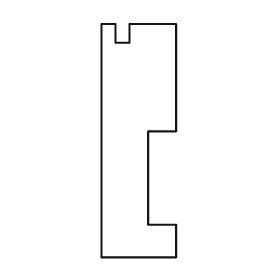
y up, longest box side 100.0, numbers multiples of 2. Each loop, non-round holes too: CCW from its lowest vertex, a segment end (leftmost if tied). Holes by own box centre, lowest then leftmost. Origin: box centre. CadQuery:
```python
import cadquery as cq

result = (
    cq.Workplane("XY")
    .moveTo(-16.0, -50.0)
    .lineTo(16.0, -50.0)
    .lineTo(16.0, -36.0)
    .lineTo(4.0, -36.0)
    .lineTo(4.0, 4.0)
    .lineTo(16.0, 4.0)
    .lineTo(16.0, 50.0)
    .lineTo(-4.0, 50.0)
    .lineTo(-4.0, 42.0)
    .lineTo(-10.0, 42.0)
    .lineTo(-10.0, 50.0)
    .lineTo(-16.0, 50.0)
    .close()
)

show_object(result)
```